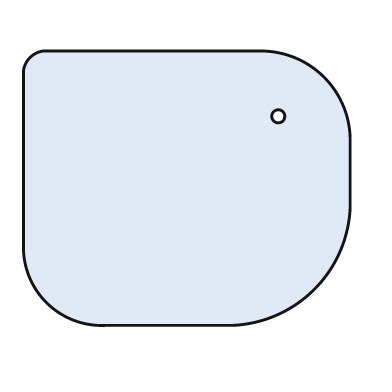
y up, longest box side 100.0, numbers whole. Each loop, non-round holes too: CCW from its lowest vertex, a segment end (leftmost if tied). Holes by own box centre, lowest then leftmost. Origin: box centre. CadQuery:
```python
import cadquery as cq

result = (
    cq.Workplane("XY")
    .moveTo(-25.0, -42.0)
    .lineTo(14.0, -42.0)
    .threePointArc((39.0, -31.0), (50.0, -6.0))
    .lineTo(50.0, 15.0)
    .threePointArc((42.0, 34.0), (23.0, 42.0))
    .lineTo(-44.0, 42.0)
    .threePointArc((-48.0, 40.0), (-50.0, 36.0))
    .lineTo(-50.0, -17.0)
    .threePointArc((-43.0, -35.0), (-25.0, -42.0))
    .close()
    .moveTo(28.0, 22.0)
    .circle(2.0)
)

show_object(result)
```